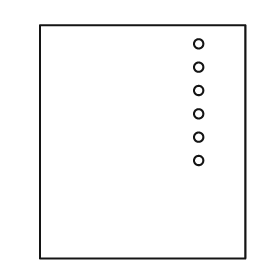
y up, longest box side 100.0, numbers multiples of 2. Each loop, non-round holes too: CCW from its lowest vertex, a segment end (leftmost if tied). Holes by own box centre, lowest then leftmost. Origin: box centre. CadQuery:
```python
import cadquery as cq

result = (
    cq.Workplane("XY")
    .moveTo(-44.0, -50.0)
    .lineTo(44.0, -50.0)
    .lineTo(44.0, 50.0)
    .lineTo(-44.0, 50.0)
    .close()
    .moveTo(24.0, -8.0)
    .circle(2.0)
    .moveTo(24.0, 2.0)
    .circle(2.0)
    .moveTo(24.0, 12.0)
    .circle(2.0)
    .moveTo(24.0, 22.0)
    .circle(2.0)
    .moveTo(24.0, 32.0)
    .circle(2.0)
    .moveTo(24.0, 42.0)
    .circle(2.0)
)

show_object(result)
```